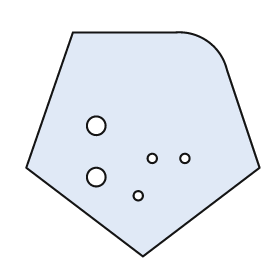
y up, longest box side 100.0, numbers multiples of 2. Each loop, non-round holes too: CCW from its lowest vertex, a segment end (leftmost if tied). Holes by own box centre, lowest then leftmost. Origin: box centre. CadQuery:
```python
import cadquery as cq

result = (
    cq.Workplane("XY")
    .moveTo(0.0, -48.0)
    .lineTo(50.0, -10.0)
    .lineTo(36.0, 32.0)
    .threePointArc((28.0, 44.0), (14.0, 48.0))
    .lineTo(-30.0, 48.0)
    .lineTo(-50.0, -10.0)
    .close()
    .moveTo(-2.0, -22.0)
    .circle(2.0)
    .moveTo(-20.0, -14.0)
    .circle(4.0)
    .moveTo(4.0, -6.0)
    .circle(2.0)
    .moveTo(18.0, -6.0)
    .circle(2.0)
    .moveTo(-20.0, 8.0)
    .circle(4.0)
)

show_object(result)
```